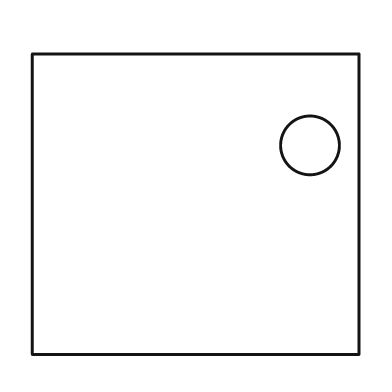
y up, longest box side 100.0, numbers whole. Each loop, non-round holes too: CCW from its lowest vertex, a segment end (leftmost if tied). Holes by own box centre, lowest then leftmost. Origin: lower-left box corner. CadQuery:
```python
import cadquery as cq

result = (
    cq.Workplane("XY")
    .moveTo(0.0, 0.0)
    .lineTo(100.0, 0.0)
    .lineTo(100.0, 92.0)
    .lineTo(0.0, 92.0)
    .close()
    .moveTo(85.0, 64.0)
    .circle(9.0)
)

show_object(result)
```